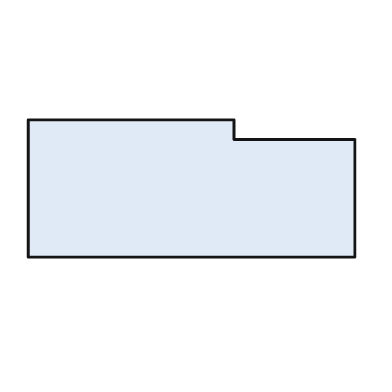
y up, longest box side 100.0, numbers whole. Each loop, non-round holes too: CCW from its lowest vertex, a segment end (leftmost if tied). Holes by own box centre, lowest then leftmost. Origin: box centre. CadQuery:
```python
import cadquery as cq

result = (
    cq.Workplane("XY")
    .moveTo(-50.0, -21.0)
    .lineTo(50.0, -21.0)
    .lineTo(50.0, 15.0)
    .lineTo(13.0, 15.0)
    .lineTo(13.0, 21.0)
    .lineTo(-50.0, 21.0)
    .close()
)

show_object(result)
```